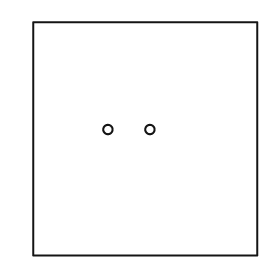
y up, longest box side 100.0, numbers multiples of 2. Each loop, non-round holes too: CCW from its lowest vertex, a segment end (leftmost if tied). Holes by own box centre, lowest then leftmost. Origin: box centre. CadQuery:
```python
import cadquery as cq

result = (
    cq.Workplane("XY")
    .moveTo(-48.0, -50.0)
    .lineTo(48.0, -50.0)
    .lineTo(48.0, 50.0)
    .lineTo(-48.0, 50.0)
    .close()
    .moveTo(-16.0, 4.0)
    .circle(2.0)
    .moveTo(2.0, 4.0)
    .circle(2.0)
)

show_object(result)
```